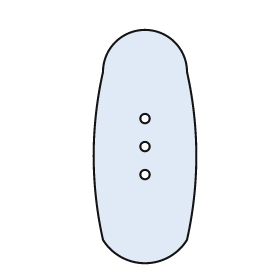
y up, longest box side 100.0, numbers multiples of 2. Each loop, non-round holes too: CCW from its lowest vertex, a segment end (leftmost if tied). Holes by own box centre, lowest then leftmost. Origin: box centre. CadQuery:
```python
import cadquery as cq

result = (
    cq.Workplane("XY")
    .moveTo(-18.0, -40.0)
    .threePointArc((0.0, -50.0), (18.0, -40.0))
    .threePointArc((22.0, -4.0), (18.0, 32.0))
    .threePointArc((0.0, 50.0), (-18.0, 32.0))
    .threePointArc((-22.0, -4.0), (-18.0, -40.0))
    .close()
    .moveTo(0.0, -12.0)
    .circle(2.0)
    .moveTo(0.0, 0.0)
    .circle(2.0)
    .moveTo(0.0, 12.0)
    .circle(2.0)
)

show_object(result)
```